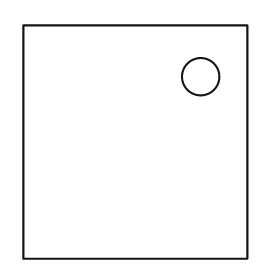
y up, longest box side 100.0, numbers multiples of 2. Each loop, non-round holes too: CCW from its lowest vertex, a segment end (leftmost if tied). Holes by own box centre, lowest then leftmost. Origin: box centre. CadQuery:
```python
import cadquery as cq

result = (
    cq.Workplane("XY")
    .moveTo(-48.0, -50.0)
    .lineTo(48.0, -50.0)
    .lineTo(48.0, 50.0)
    .lineTo(-48.0, 50.0)
    .close()
    .moveTo(28.0, 28.0)
    .circle(8.0)
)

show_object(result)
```